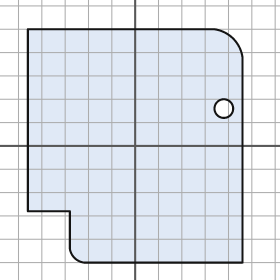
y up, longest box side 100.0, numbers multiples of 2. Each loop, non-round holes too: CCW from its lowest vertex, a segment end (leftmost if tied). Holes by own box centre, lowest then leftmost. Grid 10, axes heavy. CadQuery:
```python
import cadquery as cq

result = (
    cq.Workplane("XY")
    .moveTo(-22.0, -50.0)
    .lineTo(46.0, -50.0)
    .lineTo(46.0, 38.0)
    .threePointArc((42.0, 46.0), (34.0, 50.0))
    .lineTo(-46.0, 50.0)
    .lineTo(-46.0, -28.0)
    .lineTo(-28.0, -28.0)
    .lineTo(-28.0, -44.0)
    .threePointArc((-26.0, -48.0), (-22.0, -50.0))
    .close()
    .moveTo(38.0, 16.0)
    .circle(4.0)
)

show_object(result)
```